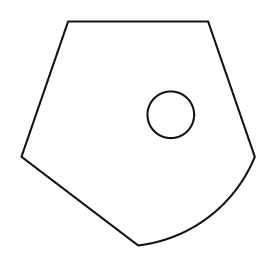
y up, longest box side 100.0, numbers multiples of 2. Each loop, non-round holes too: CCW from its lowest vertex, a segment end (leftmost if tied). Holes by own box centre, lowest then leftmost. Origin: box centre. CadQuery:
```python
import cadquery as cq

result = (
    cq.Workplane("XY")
    .moveTo(0.0, -48.0)
    .threePointArc((30.0, -36.0), (50.0, -10.0))
    .lineTo(30.0, 48.0)
    .lineTo(-30.0, 48.0)
    .lineTo(-50.0, -10.0)
    .close()
    .moveTo(14.0, 8.0)
    .circle(10.0)
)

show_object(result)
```